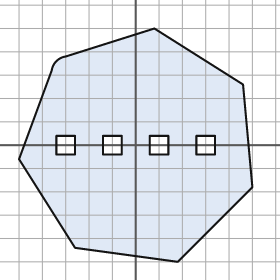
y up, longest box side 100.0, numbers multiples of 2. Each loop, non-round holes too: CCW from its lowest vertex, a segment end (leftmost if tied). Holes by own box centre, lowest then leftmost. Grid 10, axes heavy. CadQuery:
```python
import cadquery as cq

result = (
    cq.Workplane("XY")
    .moveTo(18.0, -50.0)
    .lineTo(50.0, -18.0)
    .lineTo(46.0, 26.0)
    .lineTo(8.0, 50.0)
    .lineTo(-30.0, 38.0)
    .threePointArc((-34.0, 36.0), (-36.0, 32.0))
    .lineTo(-50.0, -6.0)
    .lineTo(-26.0, -44.0)
    .close()
    .moveTo(-34.0, -4.0)
    .lineTo(-26.0, -4.0)
    .lineTo(-26.0, 4.0)
    .lineTo(-34.0, 4.0)
    .close()
    .moveTo(-14.0, -4.0)
    .lineTo(-6.0, -4.0)
    .lineTo(-6.0, 4.0)
    .lineTo(-14.0, 4.0)
    .close()
    .moveTo(6.0, -4.0)
    .lineTo(14.0, -4.0)
    .lineTo(14.0, 4.0)
    .lineTo(6.0, 4.0)
    .close()
    .moveTo(26.0, -4.0)
    .lineTo(34.0, -4.0)
    .lineTo(34.0, 4.0)
    .lineTo(26.0, 4.0)
    .close()
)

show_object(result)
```